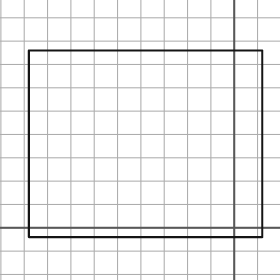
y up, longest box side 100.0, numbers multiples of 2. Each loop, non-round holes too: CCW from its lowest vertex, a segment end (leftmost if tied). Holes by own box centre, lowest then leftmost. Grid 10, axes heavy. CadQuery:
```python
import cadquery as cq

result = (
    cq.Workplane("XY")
    .moveTo(-88.0, -4.0)
    .lineTo(12.0, -4.0)
    .lineTo(12.0, 76.0)
    .lineTo(-88.0, 76.0)
    .close()
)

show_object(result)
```